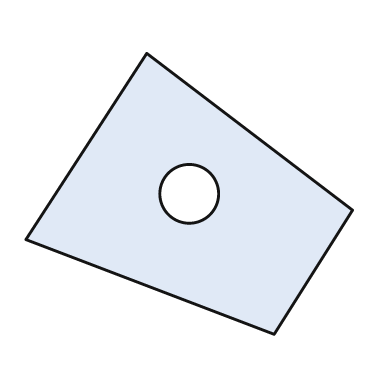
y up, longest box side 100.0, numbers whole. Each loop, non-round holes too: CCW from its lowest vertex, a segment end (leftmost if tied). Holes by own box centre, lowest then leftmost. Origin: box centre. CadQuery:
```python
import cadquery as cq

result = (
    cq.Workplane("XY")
    .moveTo(26.0, -43.0)
    .lineTo(50.0, -5.0)
    .lineTo(-13.0, 43.0)
    .lineTo(-50.0, -14.0)
    .close()
    .moveTo(0.0, 0.0)
    .circle(9.0)
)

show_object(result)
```